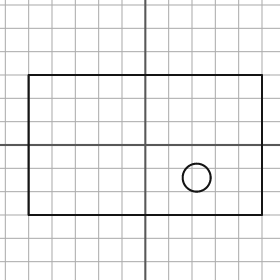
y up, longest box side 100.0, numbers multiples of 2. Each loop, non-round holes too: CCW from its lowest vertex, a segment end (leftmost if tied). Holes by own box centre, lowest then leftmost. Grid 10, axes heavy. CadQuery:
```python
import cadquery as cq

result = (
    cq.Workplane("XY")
    .moveTo(-50.0, -30.0)
    .lineTo(50.0, -30.0)
    .lineTo(50.0, 30.0)
    .lineTo(-50.0, 30.0)
    .close()
    .moveTo(22.0, -14.0)
    .circle(6.0)
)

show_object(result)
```